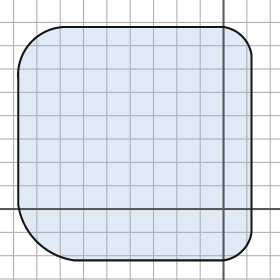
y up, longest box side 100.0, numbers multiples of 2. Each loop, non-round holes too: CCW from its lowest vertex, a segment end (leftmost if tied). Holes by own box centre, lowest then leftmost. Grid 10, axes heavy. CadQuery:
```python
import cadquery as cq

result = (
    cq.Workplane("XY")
    .moveTo(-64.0, -22.0)
    .lineTo(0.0, -22.0)
    .threePointArc((8.0, -18.0), (12.0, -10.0))
    .lineTo(12.0, 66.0)
    .threePointArc((8.0, 74.0), (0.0, 78.0))
    .lineTo(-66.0, 78.0)
    .threePointArc((-82.0, 72.0), (-88.0, 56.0))
    .lineTo(-88.0, 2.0)
    .threePointArc((-80.0, -14.0), (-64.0, -22.0))
    .close()
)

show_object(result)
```